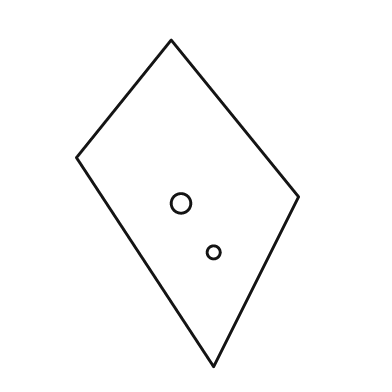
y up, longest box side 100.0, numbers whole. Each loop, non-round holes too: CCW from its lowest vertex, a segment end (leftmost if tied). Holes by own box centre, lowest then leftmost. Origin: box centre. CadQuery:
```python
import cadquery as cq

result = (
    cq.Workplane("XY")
    .moveTo(8.0, -50.0)
    .lineTo(34.0, 2.0)
    .lineTo(-5.0, 50.0)
    .lineTo(-34.0, 14.0)
    .close()
    .moveTo(8.0, -15.0)
    .circle(2.0)
    .moveTo(-2.0, 0.0)
    .circle(3.0)
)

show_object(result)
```